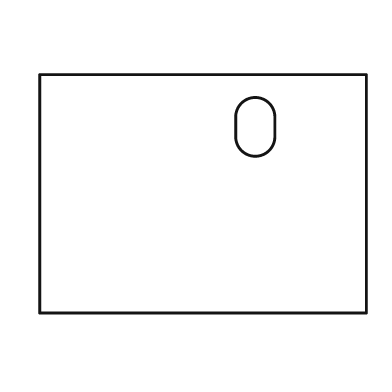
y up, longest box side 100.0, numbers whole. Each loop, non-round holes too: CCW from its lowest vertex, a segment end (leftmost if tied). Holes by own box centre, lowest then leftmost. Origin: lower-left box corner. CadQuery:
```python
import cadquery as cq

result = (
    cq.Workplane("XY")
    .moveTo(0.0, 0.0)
    .lineTo(100.0, 0.0)
    .lineTo(100.0, 73.0)
    .lineTo(0.0, 73.0)
    .close()
    .moveTo(60.0, 54.0)
    .threePointArc((66.0, 48.0), (72.0, 54.0))
    .lineTo(72.0, 60.0)
    .threePointArc((66.0, 66.0), (60.0, 60.0))
    .close()
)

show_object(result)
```